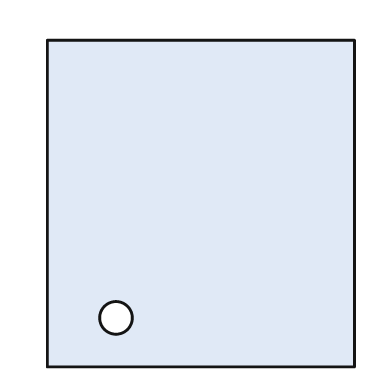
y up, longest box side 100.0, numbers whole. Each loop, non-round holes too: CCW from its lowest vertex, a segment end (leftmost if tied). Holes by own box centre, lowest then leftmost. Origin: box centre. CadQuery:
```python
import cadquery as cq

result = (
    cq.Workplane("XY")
    .moveTo(-47.0, -50.0)
    .lineTo(47.0, -50.0)
    .lineTo(47.0, 50.0)
    .lineTo(-47.0, 50.0)
    .close()
    .moveTo(-26.0, -35.0)
    .circle(5.0)
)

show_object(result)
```